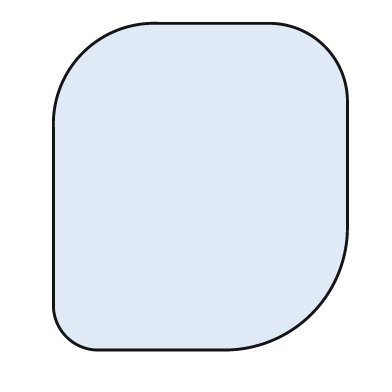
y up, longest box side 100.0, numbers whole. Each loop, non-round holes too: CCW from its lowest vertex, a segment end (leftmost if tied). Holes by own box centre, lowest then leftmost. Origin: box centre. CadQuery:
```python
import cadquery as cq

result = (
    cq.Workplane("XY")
    .moveTo(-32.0, -50.0)
    .lineTo(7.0, -50.0)
    .threePointArc((34.0, -39.0), (45.0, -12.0))
    .lineTo(45.0, 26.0)
    .threePointArc((38.0, 43.0), (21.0, 50.0))
    .lineTo(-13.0, 50.0)
    .threePointArc((-36.0, 41.0), (-45.0, 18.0))
    .lineTo(-45.0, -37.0)
    .threePointArc((-41.0, -46.0), (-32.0, -50.0))
    .close()
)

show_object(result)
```